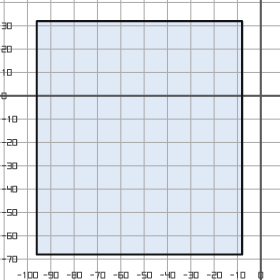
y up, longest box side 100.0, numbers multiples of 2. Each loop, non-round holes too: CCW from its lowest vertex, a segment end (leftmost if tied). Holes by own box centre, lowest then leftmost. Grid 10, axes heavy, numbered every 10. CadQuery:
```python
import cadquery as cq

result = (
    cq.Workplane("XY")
    .moveTo(-96.0, -68.0)
    .lineTo(-8.0, -68.0)
    .lineTo(-8.0, 32.0)
    .lineTo(-96.0, 32.0)
    .close()
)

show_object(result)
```